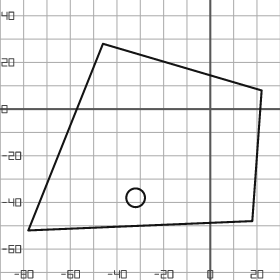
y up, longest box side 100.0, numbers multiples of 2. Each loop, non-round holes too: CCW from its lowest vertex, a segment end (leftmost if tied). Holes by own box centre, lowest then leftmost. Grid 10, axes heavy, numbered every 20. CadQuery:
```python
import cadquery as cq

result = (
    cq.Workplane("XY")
    .moveTo(-78.0, -52.0)
    .lineTo(18.0, -48.0)
    .lineTo(22.0, 8.0)
    .lineTo(-46.0, 28.0)
    .close()
    .moveTo(-32.0, -38.0)
    .circle(4.0)
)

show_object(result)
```